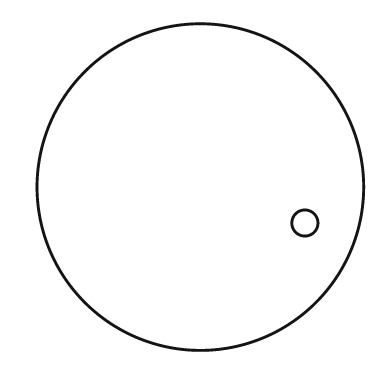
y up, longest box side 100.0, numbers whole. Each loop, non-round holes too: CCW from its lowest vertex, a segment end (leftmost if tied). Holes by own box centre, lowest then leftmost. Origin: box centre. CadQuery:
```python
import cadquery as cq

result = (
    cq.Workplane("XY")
    .moveTo(0.0, 0.0)
    .circle(50.0)
    .moveTo(32.0, -11.0)
    .circle(4.0)
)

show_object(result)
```